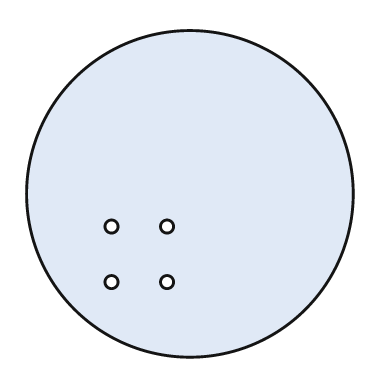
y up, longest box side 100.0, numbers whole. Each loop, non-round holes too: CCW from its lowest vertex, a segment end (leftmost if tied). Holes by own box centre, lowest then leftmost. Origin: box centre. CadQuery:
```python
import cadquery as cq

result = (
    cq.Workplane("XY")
    .moveTo(0.0, 0.0)
    .circle(50.0)
    .moveTo(-24.0, -27.0)
    .circle(2.0)
    .moveTo(-7.0, -27.0)
    .circle(2.0)
    .moveTo(-24.0, -10.0)
    .circle(2.0)
    .moveTo(-7.0, -10.0)
    .circle(2.0)
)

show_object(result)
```